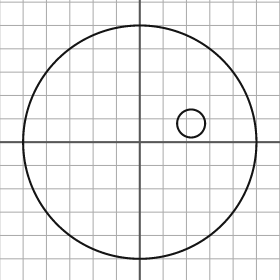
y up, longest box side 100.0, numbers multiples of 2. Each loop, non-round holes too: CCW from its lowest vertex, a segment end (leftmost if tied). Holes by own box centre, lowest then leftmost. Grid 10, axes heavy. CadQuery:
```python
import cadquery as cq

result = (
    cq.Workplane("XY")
    .moveTo(0.0, 0.0)
    .circle(50.0)
    .moveTo(22.0, 8.0)
    .circle(6.0)
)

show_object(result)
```